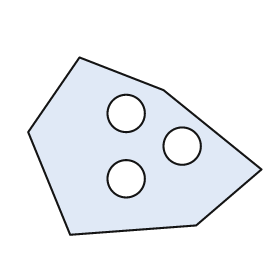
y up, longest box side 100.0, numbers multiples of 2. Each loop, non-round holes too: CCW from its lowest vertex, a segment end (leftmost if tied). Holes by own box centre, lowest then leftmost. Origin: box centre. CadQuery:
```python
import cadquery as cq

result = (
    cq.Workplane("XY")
    .moveTo(-32.0, -38.0)
    .lineTo(22.0, -34.0)
    .lineTo(50.0, -10.0)
    .lineTo(8.0, 24.0)
    .lineTo(-28.0, 38.0)
    .lineTo(-50.0, 6.0)
    .close()
    .moveTo(-8.0, -14.0)
    .circle(8.0)
    .moveTo(16.0, 0.0)
    .circle(8.0)
    .moveTo(-8.0, 14.0)
    .circle(8.0)
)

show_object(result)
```